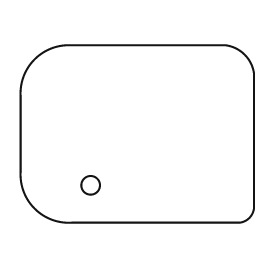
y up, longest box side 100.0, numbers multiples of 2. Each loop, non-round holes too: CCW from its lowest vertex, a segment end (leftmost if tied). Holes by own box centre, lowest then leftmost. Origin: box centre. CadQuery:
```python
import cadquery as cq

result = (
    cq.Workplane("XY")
    .moveTo(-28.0, -38.0)
    .lineTo(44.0, -38.0)
    .threePointArc((48.0, -36.0), (50.0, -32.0))
    .lineTo(50.0, 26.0)
    .threePointArc((46.0, 34.0), (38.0, 38.0))
    .lineTo(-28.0, 38.0)
    .threePointArc((-44.0, 32.0), (-50.0, 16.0))
    .lineTo(-50.0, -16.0)
    .threePointArc((-44.0, -32.0), (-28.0, -38.0))
    .close()
    .moveTo(-20.0, -22.0)
    .circle(4.0)
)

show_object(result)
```